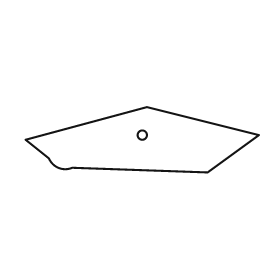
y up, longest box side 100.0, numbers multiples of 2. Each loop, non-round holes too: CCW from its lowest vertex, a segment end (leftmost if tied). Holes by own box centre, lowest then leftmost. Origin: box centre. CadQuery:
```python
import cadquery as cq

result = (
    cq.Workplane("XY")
    .moveTo(28.0, -14.0)
    .lineTo(50.0, 2.0)
    .lineTo(2.0, 14.0)
    .lineTo(-50.0, 0.0)
    .lineTo(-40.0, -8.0)
    .threePointArc((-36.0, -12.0), (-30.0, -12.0))
    .close()
    .moveTo(0.0, 2.0)
    .circle(2.0)
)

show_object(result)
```